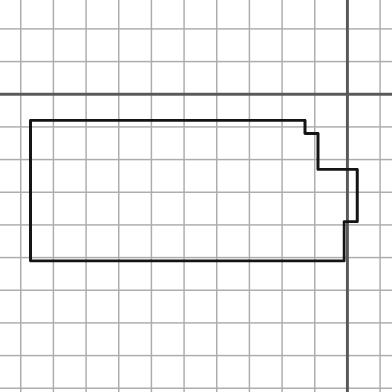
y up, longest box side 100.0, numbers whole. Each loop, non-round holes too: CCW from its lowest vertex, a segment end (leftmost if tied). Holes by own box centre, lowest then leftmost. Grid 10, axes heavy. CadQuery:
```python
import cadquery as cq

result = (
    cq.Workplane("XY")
    .moveTo(-97.0, -51.0)
    .lineTo(-1.0, -51.0)
    .lineTo(-1.0, -39.0)
    .lineTo(3.0, -39.0)
    .lineTo(3.0, -23.0)
    .lineTo(-9.0, -23.0)
    .lineTo(-9.0, -12.0)
    .lineTo(-13.0, -12.0)
    .lineTo(-13.0, -8.0)
    .lineTo(-97.0, -8.0)
    .close()
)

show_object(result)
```